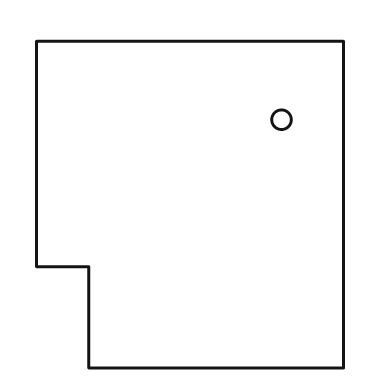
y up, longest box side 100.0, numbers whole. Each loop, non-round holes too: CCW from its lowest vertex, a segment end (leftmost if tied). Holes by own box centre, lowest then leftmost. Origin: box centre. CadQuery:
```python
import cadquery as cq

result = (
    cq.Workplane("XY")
    .moveTo(-31.0, -50.0)
    .lineTo(47.0, -50.0)
    .lineTo(47.0, 50.0)
    .lineTo(-47.0, 50.0)
    .lineTo(-47.0, -19.0)
    .lineTo(-31.0, -19.0)
    .close()
    .moveTo(28.0, 26.0)
    .circle(3.0)
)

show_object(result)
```